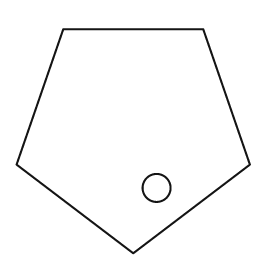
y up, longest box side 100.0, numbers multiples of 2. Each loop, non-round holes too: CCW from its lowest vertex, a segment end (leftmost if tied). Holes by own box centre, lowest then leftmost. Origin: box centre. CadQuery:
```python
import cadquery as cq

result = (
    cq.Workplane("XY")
    .moveTo(0.0, -48.0)
    .lineTo(50.0, -10.0)
    .lineTo(30.0, 48.0)
    .lineTo(-30.0, 48.0)
    .lineTo(-50.0, -10.0)
    .close()
    .moveTo(10.0, -20.0)
    .circle(6.0)
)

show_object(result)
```